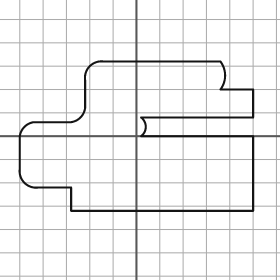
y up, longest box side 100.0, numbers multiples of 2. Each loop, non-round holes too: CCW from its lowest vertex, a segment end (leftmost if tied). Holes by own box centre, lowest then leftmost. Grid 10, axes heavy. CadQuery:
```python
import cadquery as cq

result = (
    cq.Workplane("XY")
    .moveTo(-28.0, -32.0)
    .lineTo(50.0, -32.0)
    .lineTo(50.0, 0.0)
    .lineTo(2.0, 0.0)
    .threePointArc((4.0, 4.0), (2.0, 8.0))
    .lineTo(50.0, 8.0)
    .lineTo(50.0, 20.0)
    .lineTo(36.0, 20.0)
    .threePointArc((38.0, 26.0), (36.0, 32.0))
    .lineTo(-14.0, 32.0)
    .threePointArc((-20.0, 30.0), (-22.0, 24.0))
    .lineTo(-22.0, 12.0)
    .threePointArc((-24.0, 8.0), (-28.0, 6.0))
    .lineTo(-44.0, 6.0)
    .threePointArc((-48.0, 4.0), (-50.0, 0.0))
    .lineTo(-50.0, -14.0)
    .threePointArc((-48.0, -20.0), (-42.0, -22.0))
    .lineTo(-28.0, -22.0)
    .close()
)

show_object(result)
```